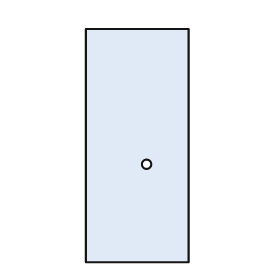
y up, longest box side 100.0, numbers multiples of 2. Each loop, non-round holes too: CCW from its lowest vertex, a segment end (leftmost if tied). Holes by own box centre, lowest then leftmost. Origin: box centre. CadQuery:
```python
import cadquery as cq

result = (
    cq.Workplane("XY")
    .moveTo(-22.0, -50.0)
    .lineTo(22.0, -50.0)
    .lineTo(22.0, 50.0)
    .lineTo(-22.0, 50.0)
    .close()
    .moveTo(4.0, -8.0)
    .circle(2.0)
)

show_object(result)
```